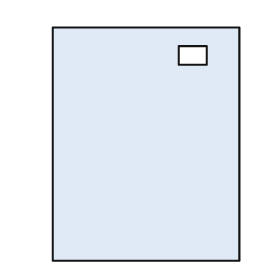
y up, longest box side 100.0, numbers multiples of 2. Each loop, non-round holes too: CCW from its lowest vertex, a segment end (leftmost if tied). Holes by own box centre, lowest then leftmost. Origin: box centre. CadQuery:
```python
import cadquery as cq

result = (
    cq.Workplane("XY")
    .moveTo(-40.0, -50.0)
    .lineTo(40.0, -50.0)
    .lineTo(40.0, 50.0)
    .lineTo(-40.0, 50.0)
    .close()
    .moveTo(14.0, 34.0)
    .lineTo(26.0, 34.0)
    .lineTo(26.0, 42.0)
    .lineTo(14.0, 42.0)
    .close()
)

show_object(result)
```